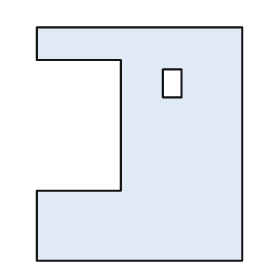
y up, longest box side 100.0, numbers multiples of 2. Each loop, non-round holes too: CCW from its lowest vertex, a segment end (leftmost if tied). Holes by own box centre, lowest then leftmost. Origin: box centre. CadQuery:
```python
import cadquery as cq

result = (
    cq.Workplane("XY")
    .moveTo(-44.0, -50.0)
    .lineTo(44.0, -50.0)
    .lineTo(44.0, 50.0)
    .lineTo(-44.0, 50.0)
    .lineTo(-44.0, 36.0)
    .lineTo(-8.0, 36.0)
    .lineTo(-8.0, -20.0)
    .lineTo(-44.0, -20.0)
    .close()
    .moveTo(10.0, 20.0)
    .lineTo(18.0, 20.0)
    .lineTo(18.0, 32.0)
    .lineTo(10.0, 32.0)
    .close()
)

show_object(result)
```